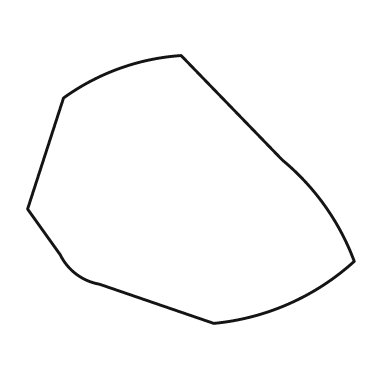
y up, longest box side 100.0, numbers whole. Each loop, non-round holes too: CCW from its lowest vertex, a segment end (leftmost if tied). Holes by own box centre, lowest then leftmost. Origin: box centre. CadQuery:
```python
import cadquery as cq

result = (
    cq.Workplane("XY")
    .moveTo(7.0, -41.0)
    .threePointArc((30.0, -35.0), (50.0, -22.0))
    .threePointArc((41.0, -5.0), (28.0, 9.0))
    .lineTo(-3.0, 41.0)
    .threePointArc((-22.0, 37.0), (-39.0, 28.0))
    .lineTo(-50.0, -6.0)
    .lineTo(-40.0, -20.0)
    .threePointArc((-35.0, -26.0), (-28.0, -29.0))
    .close()
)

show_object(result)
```